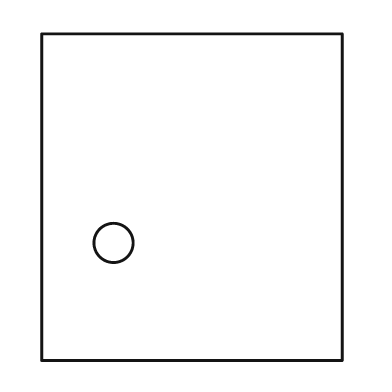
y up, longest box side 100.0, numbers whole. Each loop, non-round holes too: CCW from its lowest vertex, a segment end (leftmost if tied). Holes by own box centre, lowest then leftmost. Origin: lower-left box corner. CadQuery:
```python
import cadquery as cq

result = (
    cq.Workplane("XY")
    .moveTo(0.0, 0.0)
    .lineTo(92.0, 0.0)
    .lineTo(92.0, 100.0)
    .lineTo(0.0, 100.0)
    .close()
    .moveTo(22.0, 36.0)
    .circle(6.0)
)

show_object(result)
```